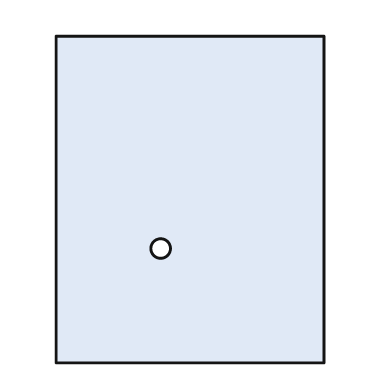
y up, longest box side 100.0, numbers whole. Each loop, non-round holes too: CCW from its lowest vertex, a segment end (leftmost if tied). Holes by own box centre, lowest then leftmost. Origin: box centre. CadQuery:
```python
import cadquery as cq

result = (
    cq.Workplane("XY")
    .moveTo(-41.0, -50.0)
    .lineTo(41.0, -50.0)
    .lineTo(41.0, 50.0)
    .lineTo(-41.0, 50.0)
    .close()
    .moveTo(-9.0, -15.0)
    .circle(3.0)
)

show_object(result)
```